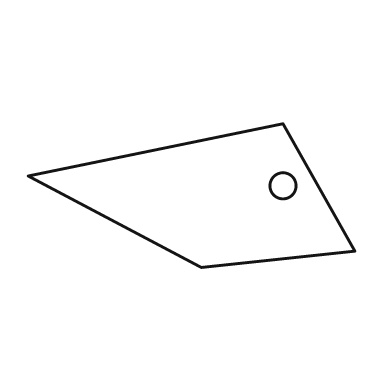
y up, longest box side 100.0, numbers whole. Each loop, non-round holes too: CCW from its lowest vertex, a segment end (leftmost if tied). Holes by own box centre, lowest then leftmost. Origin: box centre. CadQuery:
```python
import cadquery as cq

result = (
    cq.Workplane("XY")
    .moveTo(3.0, -22.0)
    .lineTo(50.0, -17.0)
    .lineTo(28.0, 22.0)
    .lineTo(-50.0, 6.0)
    .close()
    .moveTo(28.0, 3.0)
    .circle(4.0)
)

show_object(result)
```